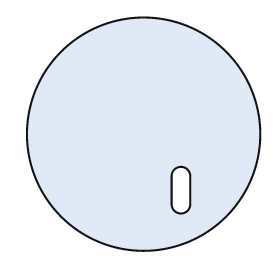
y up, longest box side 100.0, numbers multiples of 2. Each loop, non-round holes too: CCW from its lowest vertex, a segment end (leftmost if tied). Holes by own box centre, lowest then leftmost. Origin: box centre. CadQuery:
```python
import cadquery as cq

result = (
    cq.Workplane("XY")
    .moveTo(0.0, 0.0)
    .circle(50.0)
    .moveTo(12.0, -30.0)
    .threePointArc((16.0, -34.0), (20.0, -30.0))
    .lineTo(20.0, -18.0)
    .threePointArc((16.0, -14.0), (12.0, -18.0))
    .close()
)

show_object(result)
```